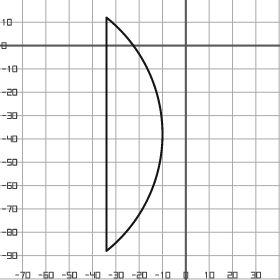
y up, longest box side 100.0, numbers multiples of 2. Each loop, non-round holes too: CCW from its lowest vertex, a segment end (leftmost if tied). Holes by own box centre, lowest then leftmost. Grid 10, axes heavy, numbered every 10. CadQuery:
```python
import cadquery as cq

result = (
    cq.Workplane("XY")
    .moveTo(-34.0, -88.0)
    .threePointArc((-10.0, -38.0), (-34.0, 12.0))
    .close()
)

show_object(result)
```